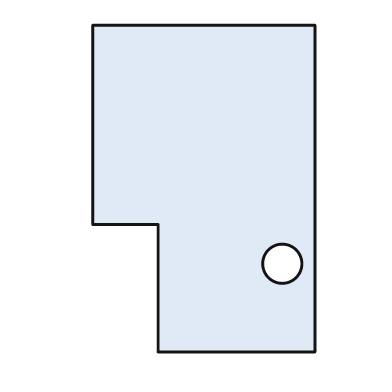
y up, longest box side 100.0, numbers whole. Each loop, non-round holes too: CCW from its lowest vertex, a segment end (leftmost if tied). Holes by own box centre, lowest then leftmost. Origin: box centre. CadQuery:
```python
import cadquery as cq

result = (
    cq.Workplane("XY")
    .moveTo(-14.0, -50.0)
    .lineTo(34.0, -50.0)
    .lineTo(34.0, 50.0)
    .lineTo(-34.0, 50.0)
    .lineTo(-34.0, -11.0)
    .lineTo(-14.0, -11.0)
    .close()
    .moveTo(24.0, -23.0)
    .circle(6.0)
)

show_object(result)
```